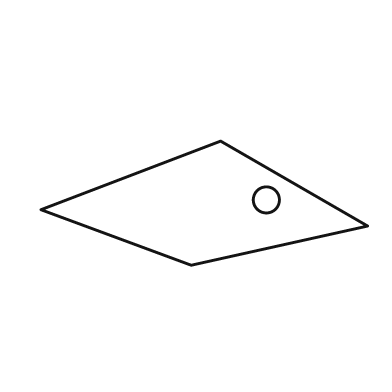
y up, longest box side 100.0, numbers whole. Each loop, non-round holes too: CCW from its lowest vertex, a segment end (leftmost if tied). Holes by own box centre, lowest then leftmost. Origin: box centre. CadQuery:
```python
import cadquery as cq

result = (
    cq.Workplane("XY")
    .moveTo(-4.0, -19.0)
    .lineTo(50.0, -7.0)
    .lineTo(5.0, 19.0)
    .lineTo(-50.0, -2.0)
    .close()
    .moveTo(19.0, 1.0)
    .circle(4.0)
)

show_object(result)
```